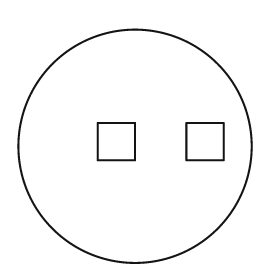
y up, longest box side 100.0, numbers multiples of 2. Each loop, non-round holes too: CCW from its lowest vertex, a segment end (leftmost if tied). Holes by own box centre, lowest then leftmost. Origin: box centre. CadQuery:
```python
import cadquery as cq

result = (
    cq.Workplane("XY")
    .moveTo(0.0, 0.0)
    .circle(50.0)
    .moveTo(-16.0, -6.0)
    .lineTo(0.0, -6.0)
    .lineTo(0.0, 10.0)
    .lineTo(-16.0, 10.0)
    .close()
    .moveTo(22.0, -6.0)
    .lineTo(38.0, -6.0)
    .lineTo(38.0, 10.0)
    .lineTo(22.0, 10.0)
    .close()
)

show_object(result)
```